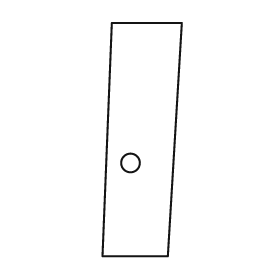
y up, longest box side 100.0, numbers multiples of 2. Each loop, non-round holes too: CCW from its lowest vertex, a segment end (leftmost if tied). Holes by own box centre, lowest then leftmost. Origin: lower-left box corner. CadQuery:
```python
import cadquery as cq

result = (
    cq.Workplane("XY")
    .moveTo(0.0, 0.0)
    .lineTo(28.0, 0.0)
    .lineTo(34.0, 100.0)
    .lineTo(4.0, 100.0)
    .close()
    .moveTo(12.0, 40.0)
    .circle(4.0)
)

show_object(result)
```